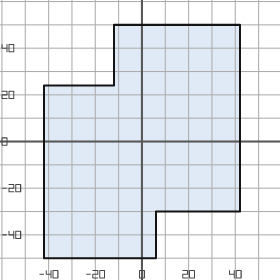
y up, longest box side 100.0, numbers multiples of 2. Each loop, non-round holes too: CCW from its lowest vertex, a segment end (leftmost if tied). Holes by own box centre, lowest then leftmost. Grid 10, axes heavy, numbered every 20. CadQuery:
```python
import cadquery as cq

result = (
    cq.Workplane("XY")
    .moveTo(-42.0, -50.0)
    .lineTo(6.0, -50.0)
    .lineTo(6.0, -30.0)
    .lineTo(42.0, -30.0)
    .lineTo(42.0, 50.0)
    .lineTo(-12.0, 50.0)
    .lineTo(-12.0, 24.0)
    .lineTo(-42.0, 24.0)
    .close()
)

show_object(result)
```